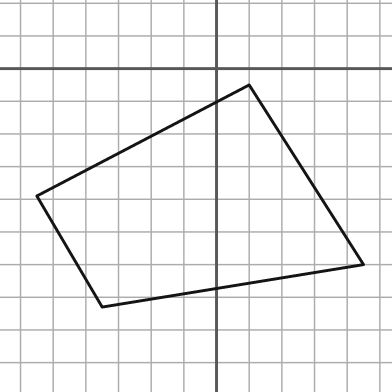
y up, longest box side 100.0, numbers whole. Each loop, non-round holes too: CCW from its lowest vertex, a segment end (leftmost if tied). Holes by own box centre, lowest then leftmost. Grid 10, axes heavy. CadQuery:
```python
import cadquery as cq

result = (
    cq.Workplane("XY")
    .moveTo(-35.0, -73.0)
    .lineTo(45.0, -60.0)
    .lineTo(10.0, -5.0)
    .lineTo(-55.0, -39.0)
    .close()
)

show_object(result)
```